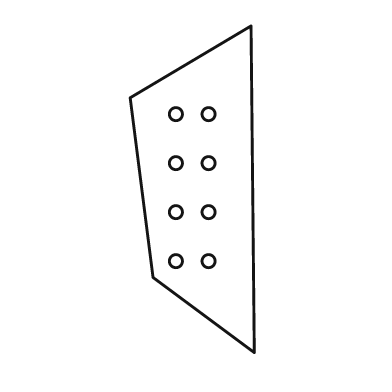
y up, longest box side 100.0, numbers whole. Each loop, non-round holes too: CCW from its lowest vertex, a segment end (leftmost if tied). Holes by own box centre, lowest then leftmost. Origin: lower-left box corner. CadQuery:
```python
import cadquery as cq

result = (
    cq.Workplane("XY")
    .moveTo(38.0, 0.0)
    .lineTo(37.0, 100.0)
    .lineTo(0.0, 78.0)
    .lineTo(7.0, 23.0)
    .close()
    .moveTo(14.0, 28.0)
    .circle(2.0)
    .moveTo(24.0, 28.0)
    .circle(2.0)
    .moveTo(14.0, 43.0)
    .circle(2.0)
    .moveTo(24.0, 43.0)
    .circle(2.0)
    .moveTo(14.0, 58.0)
    .circle(2.0)
    .moveTo(24.0, 58.0)
    .circle(2.0)
    .moveTo(14.0, 73.0)
    .circle(2.0)
    .moveTo(24.0, 73.0)
    .circle(2.0)
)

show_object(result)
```